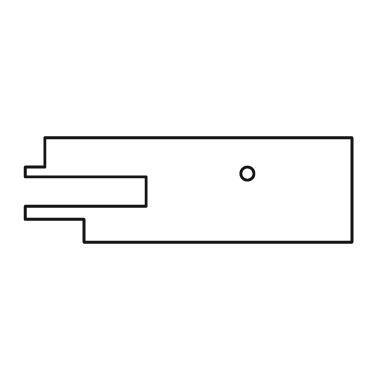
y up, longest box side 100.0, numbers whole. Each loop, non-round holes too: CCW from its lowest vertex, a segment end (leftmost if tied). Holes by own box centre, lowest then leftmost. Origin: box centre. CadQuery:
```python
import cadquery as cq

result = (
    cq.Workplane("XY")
    .moveTo(-32.0, -16.0)
    .lineTo(50.0, -16.0)
    .lineTo(50.0, 16.0)
    .lineTo(-44.0, 16.0)
    .lineTo(-44.0, 7.0)
    .lineTo(-50.0, 7.0)
    .lineTo(-50.0, 4.0)
    .lineTo(-13.0, 4.0)
    .lineTo(-13.0, -5.0)
    .lineTo(-50.0, -5.0)
    .lineTo(-50.0, -9.0)
    .lineTo(-32.0, -9.0)
    .close()
    .moveTo(18.0, 5.0)
    .circle(2.0)
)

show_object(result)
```